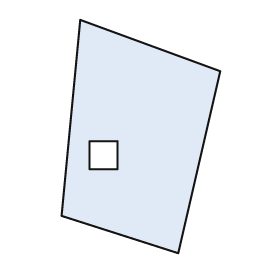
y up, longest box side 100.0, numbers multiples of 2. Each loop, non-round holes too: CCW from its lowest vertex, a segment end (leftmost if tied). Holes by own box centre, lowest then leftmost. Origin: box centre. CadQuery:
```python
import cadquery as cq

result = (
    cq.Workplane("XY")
    .moveTo(16.0, -50.0)
    .lineTo(34.0, 28.0)
    .lineTo(-26.0, 50.0)
    .lineTo(-34.0, -34.0)
    .close()
    .moveTo(-22.0, -14.0)
    .lineTo(-10.0, -14.0)
    .lineTo(-10.0, -2.0)
    .lineTo(-22.0, -2.0)
    .close()
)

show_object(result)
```